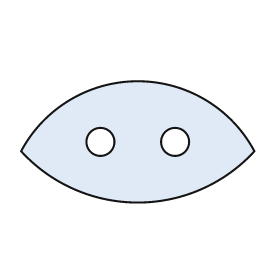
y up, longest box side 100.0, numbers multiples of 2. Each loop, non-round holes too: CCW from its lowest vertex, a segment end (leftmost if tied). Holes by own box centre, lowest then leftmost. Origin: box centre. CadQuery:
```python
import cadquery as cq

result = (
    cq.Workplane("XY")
    .moveTo(-50.0, -4.0)
    .threePointArc((0.0, -26.0), (50.0, -4.0))
    .threePointArc((0.0, 26.0), (-50.0, -4.0))
    .close()
    .moveTo(-16.0, 0.0)
    .circle(6.0)
    .moveTo(16.0, 0.0)
    .circle(6.0)
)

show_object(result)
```